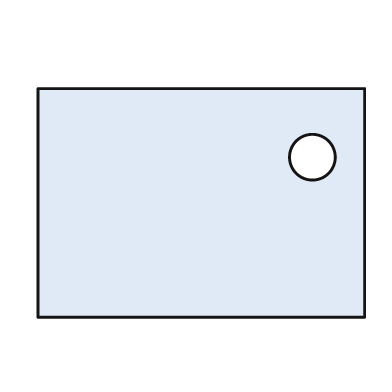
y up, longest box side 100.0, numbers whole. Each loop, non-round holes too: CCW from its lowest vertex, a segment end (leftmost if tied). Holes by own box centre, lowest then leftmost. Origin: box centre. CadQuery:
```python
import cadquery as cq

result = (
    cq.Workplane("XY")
    .moveTo(-50.0, -35.0)
    .lineTo(50.0, -35.0)
    .lineTo(50.0, 35.0)
    .lineTo(-50.0, 35.0)
    .close()
    .moveTo(34.0, 14.0)
    .circle(7.0)
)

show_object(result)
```